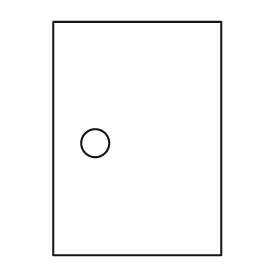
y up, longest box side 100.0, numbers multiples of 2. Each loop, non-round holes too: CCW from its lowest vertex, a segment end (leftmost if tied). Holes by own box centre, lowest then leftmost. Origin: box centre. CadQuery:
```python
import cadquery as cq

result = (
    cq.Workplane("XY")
    .moveTo(-36.0, -50.0)
    .lineTo(36.0, -50.0)
    .lineTo(36.0, 50.0)
    .lineTo(-36.0, 50.0)
    .close()
    .moveTo(-18.0, -2.0)
    .circle(6.0)
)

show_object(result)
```